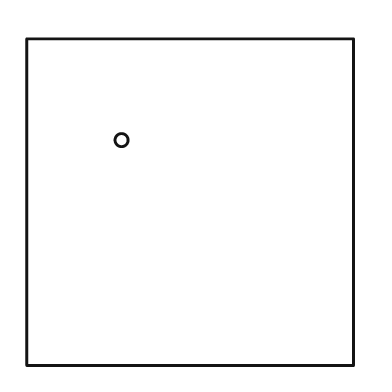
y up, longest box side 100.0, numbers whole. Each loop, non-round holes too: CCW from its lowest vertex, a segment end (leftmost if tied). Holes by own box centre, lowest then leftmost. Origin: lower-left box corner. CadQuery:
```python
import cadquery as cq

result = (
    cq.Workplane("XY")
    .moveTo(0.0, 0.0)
    .lineTo(100.0, 0.0)
    .lineTo(100.0, 100.0)
    .lineTo(0.0, 100.0)
    .close()
    .moveTo(29.0, 69.0)
    .circle(2.0)
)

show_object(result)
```